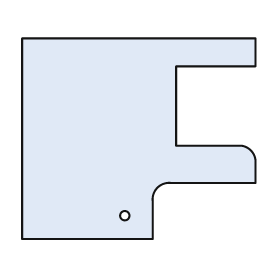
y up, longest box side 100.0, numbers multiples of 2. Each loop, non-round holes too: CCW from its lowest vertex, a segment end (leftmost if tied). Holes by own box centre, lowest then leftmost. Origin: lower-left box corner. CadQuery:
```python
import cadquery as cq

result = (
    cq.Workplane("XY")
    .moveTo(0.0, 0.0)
    .lineTo(56.0, 0.0)
    .lineTo(56.0, 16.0)
    .threePointArc((58.0, 22.0), (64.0, 24.0))
    .lineTo(100.0, 24.0)
    .lineTo(100.0, 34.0)
    .threePointArc((98.0, 38.0), (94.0, 40.0))
    .lineTo(66.0, 40.0)
    .lineTo(66.0, 74.0)
    .lineTo(100.0, 74.0)
    .lineTo(100.0, 86.0)
    .lineTo(0.0, 86.0)
    .close()
    .moveTo(44.0, 10.0)
    .circle(2.0)
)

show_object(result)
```